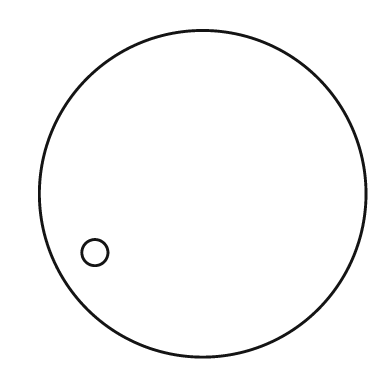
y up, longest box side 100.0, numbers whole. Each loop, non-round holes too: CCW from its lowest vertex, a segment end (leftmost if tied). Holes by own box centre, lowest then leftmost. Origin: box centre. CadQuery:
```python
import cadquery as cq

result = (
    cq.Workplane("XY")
    .moveTo(0.0, 0.0)
    .circle(50.0)
    .moveTo(-33.0, -18.0)
    .circle(4.0)
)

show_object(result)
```